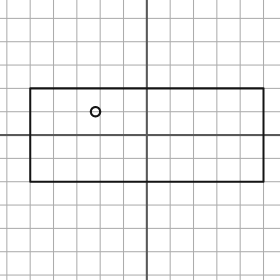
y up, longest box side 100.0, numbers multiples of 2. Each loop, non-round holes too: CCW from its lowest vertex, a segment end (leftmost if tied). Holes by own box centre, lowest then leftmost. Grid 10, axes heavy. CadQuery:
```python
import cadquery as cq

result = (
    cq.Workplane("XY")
    .moveTo(-50.0, -20.0)
    .lineTo(50.0, -20.0)
    .lineTo(50.0, 20.0)
    .lineTo(-50.0, 20.0)
    .close()
    .moveTo(-22.0, 10.0)
    .circle(2.0)
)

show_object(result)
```